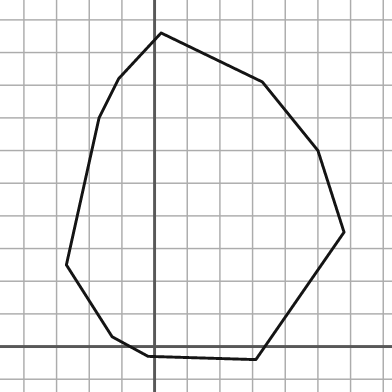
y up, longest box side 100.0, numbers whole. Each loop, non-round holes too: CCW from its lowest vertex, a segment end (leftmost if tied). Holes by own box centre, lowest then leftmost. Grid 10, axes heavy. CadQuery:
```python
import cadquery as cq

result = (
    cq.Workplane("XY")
    .moveTo(31.0, -4.0)
    .lineTo(58.0, 35.0)
    .lineTo(50.0, 60.0)
    .lineTo(33.0, 81.0)
    .lineTo(2.0, 96.0)
    .lineTo(-11.0, 82.0)
    .lineTo(-17.0, 70.0)
    .lineTo(-27.0, 25.0)
    .lineTo(-13.0, 3.0)
    .lineTo(-2.0, -3.0)
    .close()
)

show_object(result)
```